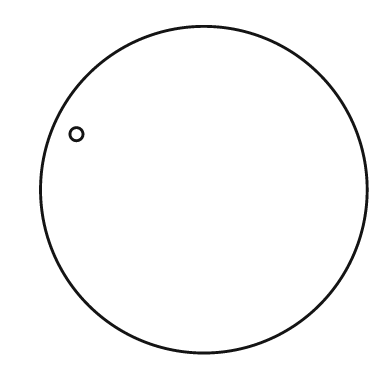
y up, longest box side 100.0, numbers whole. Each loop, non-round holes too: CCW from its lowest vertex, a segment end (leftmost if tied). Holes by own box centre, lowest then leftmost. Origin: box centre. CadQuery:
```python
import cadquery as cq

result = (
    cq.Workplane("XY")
    .moveTo(0.0, 0.0)
    .circle(50.0)
    .moveTo(-39.0, 17.0)
    .circle(2.0)
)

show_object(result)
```